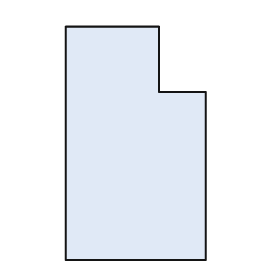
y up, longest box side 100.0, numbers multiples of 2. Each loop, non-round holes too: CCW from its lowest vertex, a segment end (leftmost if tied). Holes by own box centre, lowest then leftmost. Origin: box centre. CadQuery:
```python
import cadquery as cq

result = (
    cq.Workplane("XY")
    .moveTo(-30.0, -50.0)
    .lineTo(30.0, -50.0)
    .lineTo(30.0, 22.0)
    .lineTo(10.0, 22.0)
    .lineTo(10.0, 50.0)
    .lineTo(-30.0, 50.0)
    .close()
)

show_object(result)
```